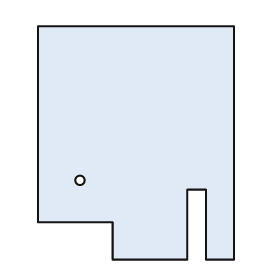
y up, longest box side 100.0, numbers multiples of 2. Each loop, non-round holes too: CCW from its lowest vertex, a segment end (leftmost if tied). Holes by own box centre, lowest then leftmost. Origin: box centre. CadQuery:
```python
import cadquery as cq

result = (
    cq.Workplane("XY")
    .moveTo(-10.0, -50.0)
    .lineTo(22.0, -50.0)
    .lineTo(22.0, -20.0)
    .lineTo(30.0, -20.0)
    .lineTo(30.0, -50.0)
    .lineTo(42.0, -50.0)
    .lineTo(42.0, 50.0)
    .lineTo(-42.0, 50.0)
    .lineTo(-42.0, -34.0)
    .lineTo(-10.0, -34.0)
    .close()
    .moveTo(-24.0, -16.0)
    .circle(2.0)
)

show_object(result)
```